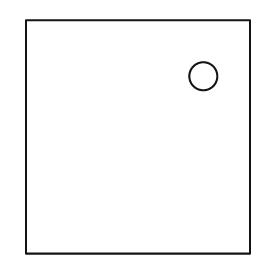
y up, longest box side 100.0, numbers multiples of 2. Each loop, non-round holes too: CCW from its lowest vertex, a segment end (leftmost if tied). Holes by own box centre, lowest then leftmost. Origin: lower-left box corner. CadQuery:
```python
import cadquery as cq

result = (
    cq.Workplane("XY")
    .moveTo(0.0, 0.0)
    .lineTo(96.0, 0.0)
    .lineTo(96.0, 100.0)
    .lineTo(0.0, 100.0)
    .close()
    .moveTo(76.0, 76.0)
    .circle(6.0)
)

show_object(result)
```